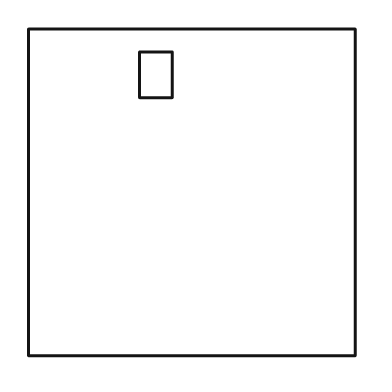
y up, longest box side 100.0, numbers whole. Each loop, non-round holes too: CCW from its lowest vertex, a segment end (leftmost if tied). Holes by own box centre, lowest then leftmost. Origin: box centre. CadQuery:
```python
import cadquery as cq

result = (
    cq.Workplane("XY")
    .moveTo(-50.0, -50.0)
    .lineTo(50.0, -50.0)
    .lineTo(50.0, 50.0)
    .lineTo(-50.0, 50.0)
    .close()
    .moveTo(-16.0, 29.0)
    .lineTo(-6.0, 29.0)
    .lineTo(-6.0, 43.0)
    .lineTo(-16.0, 43.0)
    .close()
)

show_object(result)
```